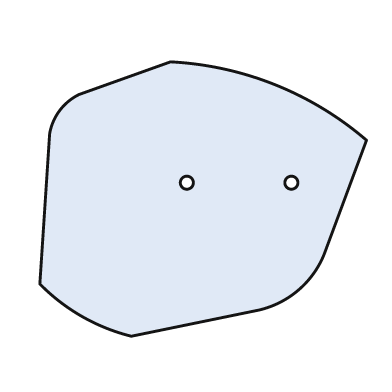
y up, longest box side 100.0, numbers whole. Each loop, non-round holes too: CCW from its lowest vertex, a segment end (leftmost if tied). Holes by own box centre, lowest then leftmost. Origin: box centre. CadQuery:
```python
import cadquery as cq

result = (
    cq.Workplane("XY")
    .moveTo(-22.0, -42.0)
    .lineTo(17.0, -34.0)
    .threePointArc((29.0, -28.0), (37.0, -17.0))
    .lineTo(50.0, 18.0)
    .threePointArc((22.0, 35.0), (-10.0, 42.0))
    .lineTo(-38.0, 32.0)
    .threePointArc((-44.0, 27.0), (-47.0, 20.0))
    .lineTo(-50.0, -26.0)
    .threePointArc((-37.0, -36.0), (-22.0, -42.0))
    .close()
    .moveTo(-5.0, 5.0)
    .circle(2.0)
    .moveTo(27.0, 5.0)
    .circle(2.0)
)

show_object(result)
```